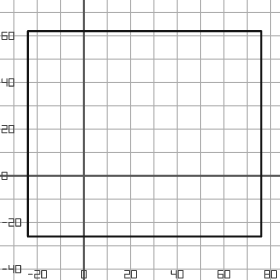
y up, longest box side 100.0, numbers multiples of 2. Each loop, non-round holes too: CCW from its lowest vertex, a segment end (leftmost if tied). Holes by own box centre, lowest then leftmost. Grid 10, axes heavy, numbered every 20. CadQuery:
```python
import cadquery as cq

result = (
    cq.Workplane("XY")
    .moveTo(-24.0, -26.0)
    .lineTo(76.0, -26.0)
    .lineTo(76.0, 62.0)
    .lineTo(-24.0, 62.0)
    .close()
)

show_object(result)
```